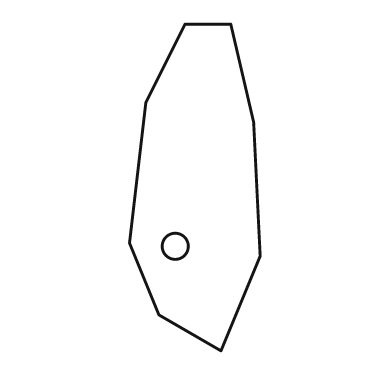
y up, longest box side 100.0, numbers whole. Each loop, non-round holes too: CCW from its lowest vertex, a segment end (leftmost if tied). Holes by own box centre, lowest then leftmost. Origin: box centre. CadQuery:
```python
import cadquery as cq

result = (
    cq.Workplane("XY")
    .moveTo(8.0, -50.0)
    .lineTo(20.0, -21.0)
    .lineTo(18.0, 20.0)
    .lineTo(11.0, 50.0)
    .lineTo(-3.0, 50.0)
    .lineTo(-15.0, 26.0)
    .lineTo(-20.0, -17.0)
    .lineTo(-11.0, -39.0)
    .close()
    .moveTo(-6.0, -18.0)
    .circle(4.0)
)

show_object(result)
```